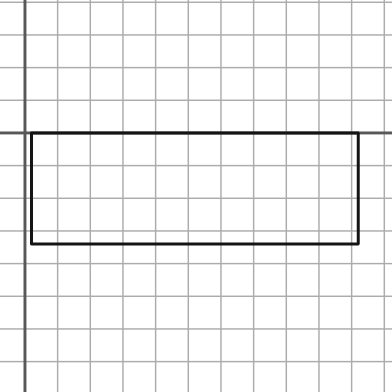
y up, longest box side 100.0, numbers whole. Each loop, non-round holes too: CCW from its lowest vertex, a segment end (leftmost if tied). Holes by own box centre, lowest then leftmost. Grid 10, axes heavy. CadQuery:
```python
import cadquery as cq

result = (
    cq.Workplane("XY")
    .moveTo(2.0, -34.0)
    .lineTo(102.0, -34.0)
    .lineTo(102.0, 0.0)
    .lineTo(2.0, 0.0)
    .close()
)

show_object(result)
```